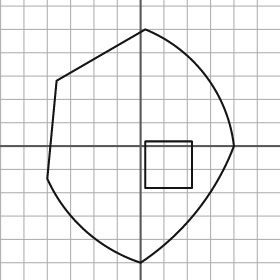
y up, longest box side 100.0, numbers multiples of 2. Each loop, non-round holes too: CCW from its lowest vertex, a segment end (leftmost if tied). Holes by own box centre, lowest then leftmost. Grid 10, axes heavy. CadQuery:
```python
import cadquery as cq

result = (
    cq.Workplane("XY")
    .moveTo(0.0, -50.0)
    .threePointArc((24.0, -28.0), (40.0, 0.0))
    .threePointArc((28.0, 30.0), (2.0, 50.0))
    .lineTo(-36.0, 28.0)
    .lineTo(-40.0, -14.0)
    .threePointArc((-24.0, -36.0), (0.0, -50.0))
    .close()
    .moveTo(2.0, -18.0)
    .lineTo(22.0, -18.0)
    .lineTo(22.0, 2.0)
    .lineTo(2.0, 2.0)
    .close()
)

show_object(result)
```